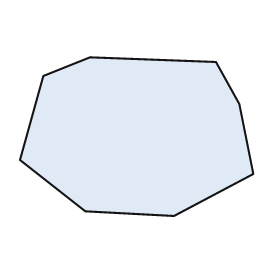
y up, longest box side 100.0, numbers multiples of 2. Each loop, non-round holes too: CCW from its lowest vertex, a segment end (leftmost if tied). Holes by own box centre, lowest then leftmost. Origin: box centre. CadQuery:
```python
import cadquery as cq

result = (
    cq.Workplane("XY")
    .moveTo(16.0, -34.0)
    .lineTo(50.0, -16.0)
    .lineTo(44.0, 14.0)
    .lineTo(34.0, 32.0)
    .lineTo(-20.0, 34.0)
    .lineTo(-40.0, 26.0)
    .lineTo(-50.0, -10.0)
    .lineTo(-22.0, -32.0)
    .close()
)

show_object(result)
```